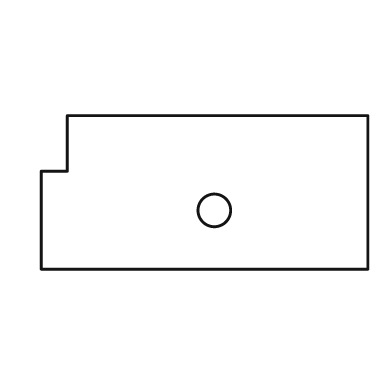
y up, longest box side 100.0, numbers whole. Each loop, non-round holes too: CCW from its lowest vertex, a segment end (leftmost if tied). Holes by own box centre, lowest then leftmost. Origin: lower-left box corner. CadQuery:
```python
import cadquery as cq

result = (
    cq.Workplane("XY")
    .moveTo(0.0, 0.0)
    .lineTo(100.0, 0.0)
    .lineTo(100.0, 47.0)
    .lineTo(8.0, 47.0)
    .lineTo(8.0, 30.0)
    .lineTo(0.0, 30.0)
    .close()
    .moveTo(53.0, 18.0)
    .circle(5.0)
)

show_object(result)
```